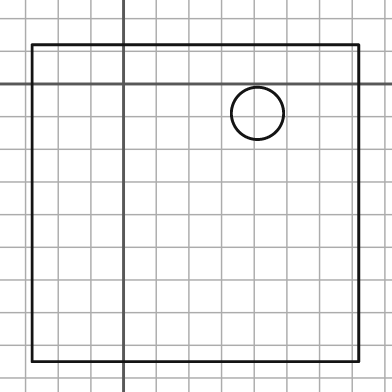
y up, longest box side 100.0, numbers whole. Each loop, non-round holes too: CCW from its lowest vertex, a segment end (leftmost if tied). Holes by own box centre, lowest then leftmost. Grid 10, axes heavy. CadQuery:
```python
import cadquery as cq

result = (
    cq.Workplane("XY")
    .moveTo(-28.0, -85.0)
    .lineTo(72.0, -85.0)
    .lineTo(72.0, 12.0)
    .lineTo(-28.0, 12.0)
    .close()
    .moveTo(41.0, -9.0)
    .circle(8.0)
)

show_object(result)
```